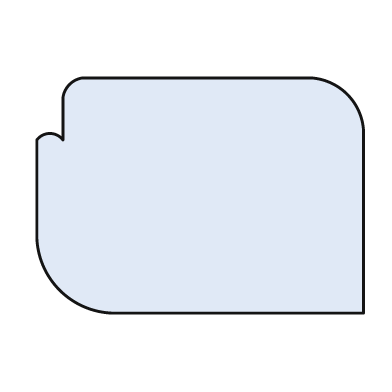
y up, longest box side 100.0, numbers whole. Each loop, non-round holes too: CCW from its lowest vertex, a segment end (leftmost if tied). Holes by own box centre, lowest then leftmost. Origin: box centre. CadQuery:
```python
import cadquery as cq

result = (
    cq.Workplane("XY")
    .moveTo(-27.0, -36.0)
    .lineTo(50.0, -36.0)
    .lineTo(50.0, 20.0)
    .threePointArc((45.0, 31.0), (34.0, 36.0))
    .lineTo(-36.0, 36.0)
    .threePointArc((-40.0, 34.0), (-42.0, 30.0))
    .lineTo(-42.0, 17.0)
    .threePointArc((-46.0, 19.0), (-50.0, 17.0))
    .lineTo(-50.0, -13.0)
    .threePointArc((-43.0, -29.0), (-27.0, -36.0))
    .close()
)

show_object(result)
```